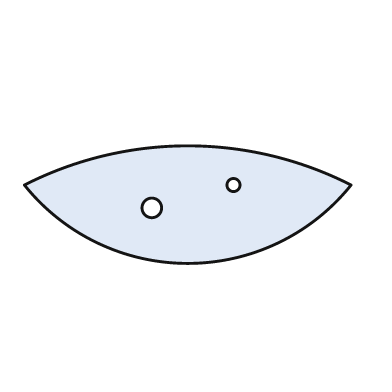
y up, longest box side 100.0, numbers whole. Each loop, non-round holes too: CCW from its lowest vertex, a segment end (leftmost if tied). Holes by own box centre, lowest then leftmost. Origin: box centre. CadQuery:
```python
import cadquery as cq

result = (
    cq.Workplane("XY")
    .moveTo(-50.0, 6.0)
    .threePointArc((0.0, -18.0), (50.0, 6.0))
    .threePointArc((0.0, 18.0), (-50.0, 6.0))
    .close()
    .moveTo(-11.0, -1.0)
    .circle(3.0)
    .moveTo(14.0, 6.0)
    .circle(2.0)
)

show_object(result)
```